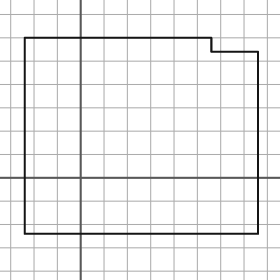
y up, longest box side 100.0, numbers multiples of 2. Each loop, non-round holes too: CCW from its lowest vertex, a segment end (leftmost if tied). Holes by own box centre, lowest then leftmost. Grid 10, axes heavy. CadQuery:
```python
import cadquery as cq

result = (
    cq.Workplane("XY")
    .moveTo(-24.0, -24.0)
    .lineTo(76.0, -24.0)
    .lineTo(76.0, 54.0)
    .lineTo(56.0, 54.0)
    .lineTo(56.0, 60.0)
    .lineTo(-24.0, 60.0)
    .close()
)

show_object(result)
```